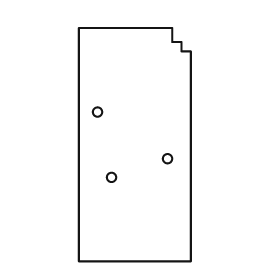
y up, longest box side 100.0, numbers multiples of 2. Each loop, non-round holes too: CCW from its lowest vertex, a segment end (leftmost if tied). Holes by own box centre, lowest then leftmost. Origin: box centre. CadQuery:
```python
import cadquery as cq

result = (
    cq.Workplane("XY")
    .moveTo(-24.0, -50.0)
    .lineTo(24.0, -50.0)
    .lineTo(24.0, 40.0)
    .lineTo(20.0, 40.0)
    .lineTo(20.0, 44.0)
    .lineTo(16.0, 44.0)
    .lineTo(16.0, 50.0)
    .lineTo(-24.0, 50.0)
    .close()
    .moveTo(-10.0, -14.0)
    .circle(2.0)
    .moveTo(14.0, -6.0)
    .circle(2.0)
    .moveTo(-16.0, 14.0)
    .circle(2.0)
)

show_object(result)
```